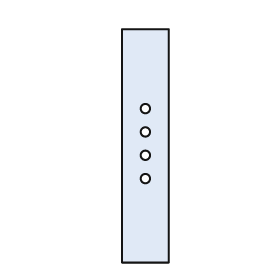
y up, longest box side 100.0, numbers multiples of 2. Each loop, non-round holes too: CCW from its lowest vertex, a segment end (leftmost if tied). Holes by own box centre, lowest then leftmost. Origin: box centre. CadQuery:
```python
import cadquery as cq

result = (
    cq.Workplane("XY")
    .moveTo(-10.0, -50.0)
    .lineTo(10.0, -50.0)
    .lineTo(10.0, 50.0)
    .lineTo(-10.0, 50.0)
    .close()
    .moveTo(0.0, -14.0)
    .circle(2.0)
    .moveTo(0.0, -4.0)
    .circle(2.0)
    .moveTo(0.0, 6.0)
    .circle(2.0)
    .moveTo(0.0, 16.0)
    .circle(2.0)
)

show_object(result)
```